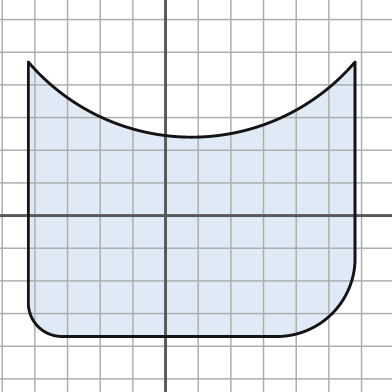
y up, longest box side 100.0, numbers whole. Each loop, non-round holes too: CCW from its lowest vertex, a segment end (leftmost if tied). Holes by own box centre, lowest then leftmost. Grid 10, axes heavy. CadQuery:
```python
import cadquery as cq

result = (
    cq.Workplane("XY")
    .moveTo(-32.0, -37.0)
    .lineTo(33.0, -37.0)
    .threePointArc((51.0, -30.0), (58.0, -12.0))
    .lineTo(58.0, 47.0)
    .threePointArc((8.0, 24.0), (-42.0, 47.0))
    .lineTo(-42.0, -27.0)
    .threePointArc((-39.0, -34.0), (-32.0, -37.0))
    .close()
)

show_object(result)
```